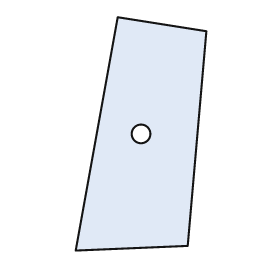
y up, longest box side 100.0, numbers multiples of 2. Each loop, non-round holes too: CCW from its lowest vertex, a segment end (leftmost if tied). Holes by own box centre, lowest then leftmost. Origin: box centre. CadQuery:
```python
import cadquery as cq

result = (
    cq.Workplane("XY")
    .moveTo(-28.0, -50.0)
    .lineTo(20.0, -48.0)
    .lineTo(28.0, 44.0)
    .lineTo(-10.0, 50.0)
    .close()
    .moveTo(0.0, 0.0)
    .circle(4.0)
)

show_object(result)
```